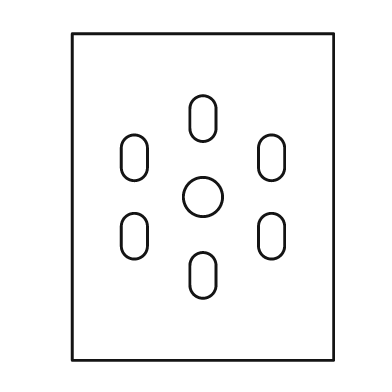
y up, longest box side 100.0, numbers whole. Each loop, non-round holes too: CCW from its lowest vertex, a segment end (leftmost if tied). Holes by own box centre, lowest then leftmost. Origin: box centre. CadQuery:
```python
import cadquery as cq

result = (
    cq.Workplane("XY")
    .moveTo(-40.0, -50.0)
    .lineTo(40.0, -50.0)
    .lineTo(40.0, 50.0)
    .lineTo(-40.0, 50.0)
    .close()
    .moveTo(-4.0, -27.0)
    .threePointArc((0.0, -31.0), (4.0, -27.0))
    .lineTo(4.0, -21.0)
    .threePointArc((0.0, -17.0), (-4.0, -21.0))
    .close()
    .moveTo(-25.0, -15.0)
    .threePointArc((-21.0, -19.0), (-17.0, -15.0))
    .lineTo(-17.0, -9.0)
    .threePointArc((-21.0, -5.0), (-25.0, -9.0))
    .close()
    .moveTo(17.0, -15.0)
    .threePointArc((21.0, -19.0), (25.0, -15.0))
    .lineTo(25.0, -9.0)
    .threePointArc((21.0, -5.0), (17.0, -9.0))
    .close()
    .moveTo(0.0, 0.0)
    .circle(6.0)
    .moveTo(-25.0, 9.0)
    .threePointArc((-21.0, 5.0), (-17.0, 9.0))
    .lineTo(-17.0, 15.0)
    .threePointArc((-21.0, 19.0), (-25.0, 15.0))
    .close()
    .moveTo(17.0, 9.0)
    .threePointArc((21.0, 5.0), (25.0, 9.0))
    .lineTo(25.0, 15.0)
    .threePointArc((21.0, 19.0), (17.0, 15.0))
    .close()
    .moveTo(-4.0, 21.0)
    .threePointArc((0.0, 17.0), (4.0, 21.0))
    .lineTo(4.0, 27.0)
    .threePointArc((0.0, 31.0), (-4.0, 27.0))
    .close()
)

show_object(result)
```